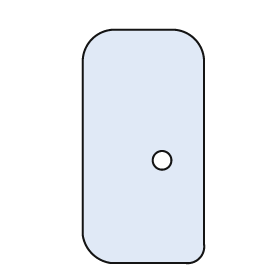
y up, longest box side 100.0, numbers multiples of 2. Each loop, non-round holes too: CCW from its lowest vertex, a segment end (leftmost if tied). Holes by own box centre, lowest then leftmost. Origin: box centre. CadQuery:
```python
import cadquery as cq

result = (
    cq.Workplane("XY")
    .moveTo(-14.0, -50.0)
    .lineTo(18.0, -50.0)
    .threePointArc((24.0, -48.0), (26.0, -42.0))
    .lineTo(26.0, 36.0)
    .threePointArc((22.0, 46.0), (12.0, 50.0))
    .lineTo(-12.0, 50.0)
    .threePointArc((-22.0, 46.0), (-26.0, 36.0))
    .lineTo(-26.0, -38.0)
    .threePointArc((-22.0, -46.0), (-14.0, -50.0))
    .close()
    .moveTo(8.0, -6.0)
    .circle(4.0)
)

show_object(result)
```